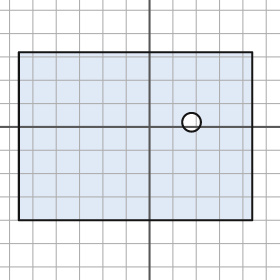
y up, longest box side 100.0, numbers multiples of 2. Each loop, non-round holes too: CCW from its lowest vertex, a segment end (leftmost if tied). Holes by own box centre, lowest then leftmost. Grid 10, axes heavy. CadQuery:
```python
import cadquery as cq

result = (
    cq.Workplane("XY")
    .moveTo(-56.0, -40.0)
    .lineTo(44.0, -40.0)
    .lineTo(44.0, 32.0)
    .lineTo(-56.0, 32.0)
    .close()
    .moveTo(18.0, 2.0)
    .circle(4.0)
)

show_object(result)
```